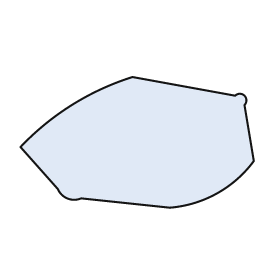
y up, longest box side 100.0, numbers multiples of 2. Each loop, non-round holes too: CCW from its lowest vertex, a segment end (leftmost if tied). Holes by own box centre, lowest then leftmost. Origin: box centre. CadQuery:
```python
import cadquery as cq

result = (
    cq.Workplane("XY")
    .moveTo(14.0, -28.0)
    .threePointArc((34.0, -22.0), (50.0, -8.0))
    .lineTo(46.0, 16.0)
    .threePointArc((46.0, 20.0), (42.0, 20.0))
    .lineTo(-2.0, 28.0)
    .threePointArc((-28.0, 16.0), (-50.0, -2.0))
    .lineTo(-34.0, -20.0)
    .threePointArc((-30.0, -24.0), (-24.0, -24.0))
    .close()
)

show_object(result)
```